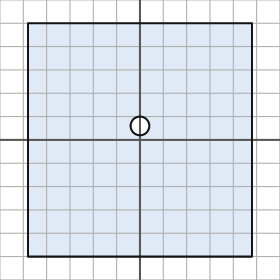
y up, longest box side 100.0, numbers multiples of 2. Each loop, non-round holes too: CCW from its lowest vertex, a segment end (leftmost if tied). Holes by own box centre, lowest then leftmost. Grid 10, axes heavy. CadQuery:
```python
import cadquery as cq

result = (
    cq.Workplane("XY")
    .moveTo(-48.0, -50.0)
    .lineTo(48.0, -50.0)
    .lineTo(48.0, 50.0)
    .lineTo(-48.0, 50.0)
    .close()
    .moveTo(0.0, 6.0)
    .circle(4.0)
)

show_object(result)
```